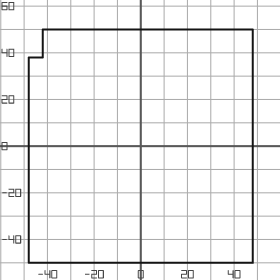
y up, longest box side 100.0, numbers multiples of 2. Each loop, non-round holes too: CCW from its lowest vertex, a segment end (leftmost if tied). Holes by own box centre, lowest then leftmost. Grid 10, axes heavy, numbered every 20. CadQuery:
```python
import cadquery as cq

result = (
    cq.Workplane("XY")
    .moveTo(-48.0, -50.0)
    .lineTo(48.0, -50.0)
    .lineTo(48.0, 50.0)
    .lineTo(-42.0, 50.0)
    .lineTo(-42.0, 38.0)
    .lineTo(-48.0, 38.0)
    .close()
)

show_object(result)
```